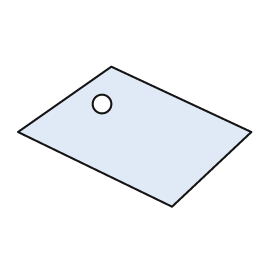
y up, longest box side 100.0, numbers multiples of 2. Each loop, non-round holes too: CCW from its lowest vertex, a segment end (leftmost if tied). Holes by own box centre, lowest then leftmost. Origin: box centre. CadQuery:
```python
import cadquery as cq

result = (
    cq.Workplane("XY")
    .moveTo(16.0, -30.0)
    .lineTo(50.0, 2.0)
    .lineTo(-10.0, 30.0)
    .lineTo(-50.0, 2.0)
    .close()
    .moveTo(-14.0, 14.0)
    .circle(4.0)
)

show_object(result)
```